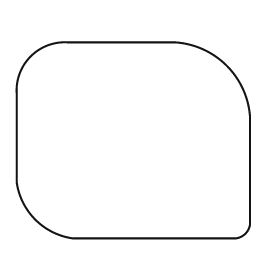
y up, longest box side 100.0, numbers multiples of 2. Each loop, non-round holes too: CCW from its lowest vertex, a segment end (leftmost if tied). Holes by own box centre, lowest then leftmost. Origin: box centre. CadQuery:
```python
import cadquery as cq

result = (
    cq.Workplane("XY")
    .moveTo(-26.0, -42.0)
    .lineTo(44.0, -42.0)
    .threePointArc((48.0, -40.0), (50.0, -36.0))
    .lineTo(50.0, 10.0)
    .threePointArc((40.0, 32.0), (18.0, 42.0))
    .lineTo(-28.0, 42.0)
    .threePointArc((-44.0, 36.0), (-50.0, 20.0))
    .lineTo(-50.0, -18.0)
    .threePointArc((-42.0, -34.0), (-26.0, -42.0))
    .close()
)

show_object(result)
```